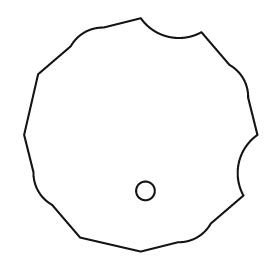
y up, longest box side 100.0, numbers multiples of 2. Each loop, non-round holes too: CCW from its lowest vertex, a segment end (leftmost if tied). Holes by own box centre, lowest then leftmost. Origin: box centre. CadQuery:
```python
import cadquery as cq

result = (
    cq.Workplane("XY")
    .moveTo(0.0, -50.0)
    .lineTo(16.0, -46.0)
    .threePointArc((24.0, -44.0), (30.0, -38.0))
    .lineTo(44.0, -26.0)
    .threePointArc((42.0, -12.0), (50.0, 0.0))
    .lineTo(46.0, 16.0)
    .threePointArc((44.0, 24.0), (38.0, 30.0))
    .lineTo(26.0, 44.0)
    .threePointArc((12.0, 42.0), (0.0, 50.0))
    .lineTo(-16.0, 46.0)
    .threePointArc((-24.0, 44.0), (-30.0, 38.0))
    .lineTo(-44.0, 26.0)
    .lineTo(-50.0, 0.0)
    .lineTo(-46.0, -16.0)
    .threePointArc((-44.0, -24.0), (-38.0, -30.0))
    .lineTo(-26.0, -44.0)
    .close()
    .moveTo(2.0, -24.0)
    .circle(4.0)
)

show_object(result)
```